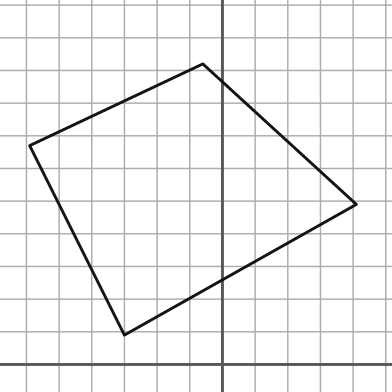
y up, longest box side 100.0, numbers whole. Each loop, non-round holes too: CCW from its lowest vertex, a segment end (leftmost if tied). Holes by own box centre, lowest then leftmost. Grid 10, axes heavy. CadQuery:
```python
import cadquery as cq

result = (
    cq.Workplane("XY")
    .moveTo(-30.0, 9.0)
    .lineTo(41.0, 49.0)
    .lineTo(-6.0, 92.0)
    .lineTo(-59.0, 67.0)
    .close()
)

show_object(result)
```